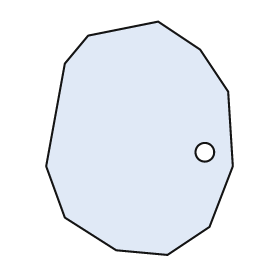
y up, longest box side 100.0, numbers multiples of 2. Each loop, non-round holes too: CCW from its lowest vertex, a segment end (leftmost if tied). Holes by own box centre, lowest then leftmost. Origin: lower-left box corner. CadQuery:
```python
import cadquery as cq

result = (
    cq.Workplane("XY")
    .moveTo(52.0, 0.0)
    .lineTo(70.0, 12.0)
    .lineTo(80.0, 38.0)
    .lineTo(78.0, 70.0)
    .lineTo(66.0, 88.0)
    .lineTo(48.0, 100.0)
    .lineTo(18.0, 94.0)
    .lineTo(8.0, 82.0)
    .lineTo(0.0, 38.0)
    .lineTo(8.0, 16.0)
    .lineTo(30.0, 2.0)
    .close()
    .moveTo(68.0, 44.0)
    .circle(4.0)
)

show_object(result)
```